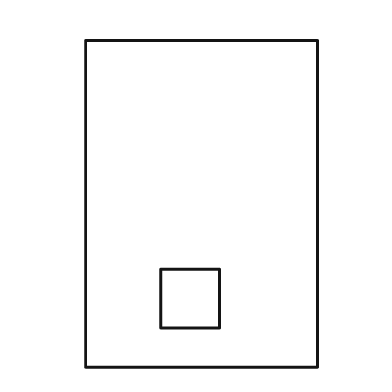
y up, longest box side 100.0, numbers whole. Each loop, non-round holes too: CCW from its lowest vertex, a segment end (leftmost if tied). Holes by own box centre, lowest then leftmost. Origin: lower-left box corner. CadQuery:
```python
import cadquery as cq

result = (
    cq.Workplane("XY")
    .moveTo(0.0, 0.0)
    .lineTo(71.0, 0.0)
    .lineTo(71.0, 100.0)
    .lineTo(0.0, 100.0)
    .close()
    .moveTo(23.0, 12.0)
    .lineTo(41.0, 12.0)
    .lineTo(41.0, 30.0)
    .lineTo(23.0, 30.0)
    .close()
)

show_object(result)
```